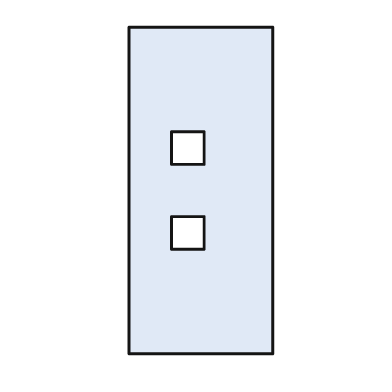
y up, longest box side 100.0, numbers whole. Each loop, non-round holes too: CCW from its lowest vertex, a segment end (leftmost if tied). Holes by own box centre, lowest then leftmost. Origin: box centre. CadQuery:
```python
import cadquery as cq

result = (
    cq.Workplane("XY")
    .moveTo(-22.0, -50.0)
    .lineTo(22.0, -50.0)
    .lineTo(22.0, 50.0)
    .lineTo(-22.0, 50.0)
    .close()
    .moveTo(-9.0, -18.0)
    .lineTo(1.0, -18.0)
    .lineTo(1.0, -8.0)
    .lineTo(-9.0, -8.0)
    .close()
    .moveTo(-9.0, 8.0)
    .lineTo(1.0, 8.0)
    .lineTo(1.0, 18.0)
    .lineTo(-9.0, 18.0)
    .close()
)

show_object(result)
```